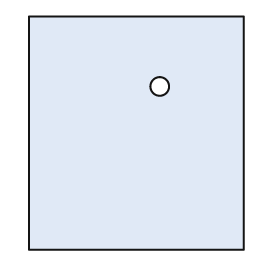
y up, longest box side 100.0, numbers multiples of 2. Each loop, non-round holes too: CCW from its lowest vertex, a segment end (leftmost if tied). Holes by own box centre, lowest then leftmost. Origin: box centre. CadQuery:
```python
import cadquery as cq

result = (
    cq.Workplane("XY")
    .moveTo(-46.0, -50.0)
    .lineTo(46.0, -50.0)
    .lineTo(46.0, 50.0)
    .lineTo(-46.0, 50.0)
    .close()
    .moveTo(10.0, 20.0)
    .circle(4.0)
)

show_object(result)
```